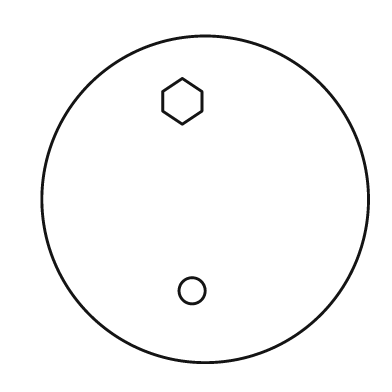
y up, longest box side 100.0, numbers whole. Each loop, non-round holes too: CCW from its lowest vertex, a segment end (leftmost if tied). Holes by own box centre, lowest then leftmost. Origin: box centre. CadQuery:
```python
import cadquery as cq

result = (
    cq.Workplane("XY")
    .moveTo(0.0, 0.0)
    .circle(50.0)
    .moveTo(-4.0, -28.0)
    .circle(4.0)
    .moveTo(-7.0, 23.0)
    .lineTo(-1.0, 27.0)
    .lineTo(-1.0, 33.0)
    .lineTo(-7.0, 37.0)
    .lineTo(-13.0, 33.0)
    .lineTo(-13.0, 27.0)
    .close()
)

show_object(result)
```